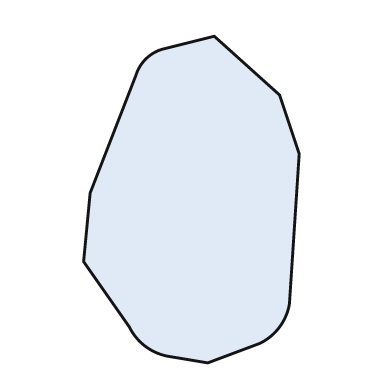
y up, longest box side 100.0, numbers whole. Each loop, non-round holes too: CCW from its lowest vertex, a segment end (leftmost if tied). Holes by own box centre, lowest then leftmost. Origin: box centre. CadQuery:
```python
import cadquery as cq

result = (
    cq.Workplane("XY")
    .moveTo(5.0, -50.0)
    .lineTo(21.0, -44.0)
    .threePointArc((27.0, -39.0), (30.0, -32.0))
    .lineTo(33.0, 14.0)
    .lineTo(27.0, 32.0)
    .lineTo(7.0, 50.0)
    .lineTo(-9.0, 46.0)
    .threePointArc((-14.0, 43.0), (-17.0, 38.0))
    .lineTo(-31.0, 2.0)
    .lineTo(-33.0, -19.0)
    .lineTo(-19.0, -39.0)
    .threePointArc((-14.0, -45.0), (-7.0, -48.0))
    .close()
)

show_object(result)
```